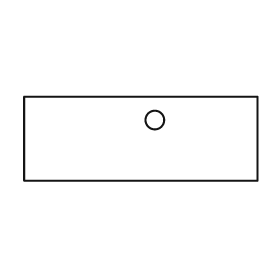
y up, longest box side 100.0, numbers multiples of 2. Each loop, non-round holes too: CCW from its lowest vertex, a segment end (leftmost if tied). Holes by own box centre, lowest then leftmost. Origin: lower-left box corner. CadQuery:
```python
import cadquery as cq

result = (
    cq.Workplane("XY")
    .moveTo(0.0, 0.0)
    .lineTo(100.0, 0.0)
    .lineTo(100.0, 36.0)
    .lineTo(0.0, 36.0)
    .close()
    .moveTo(56.0, 26.0)
    .circle(4.0)
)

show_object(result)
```